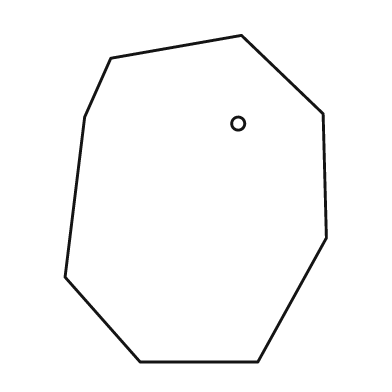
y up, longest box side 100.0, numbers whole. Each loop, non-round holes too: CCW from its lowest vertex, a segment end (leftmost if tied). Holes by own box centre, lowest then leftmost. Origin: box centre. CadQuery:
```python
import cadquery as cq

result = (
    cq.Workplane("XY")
    .moveTo(-17.0, -50.0)
    .lineTo(19.0, -50.0)
    .lineTo(40.0, -12.0)
    .lineTo(39.0, 26.0)
    .lineTo(14.0, 50.0)
    .lineTo(-26.0, 43.0)
    .lineTo(-34.0, 25.0)
    .lineTo(-40.0, -24.0)
    .close()
    .moveTo(13.0, 23.0)
    .circle(2.0)
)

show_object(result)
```